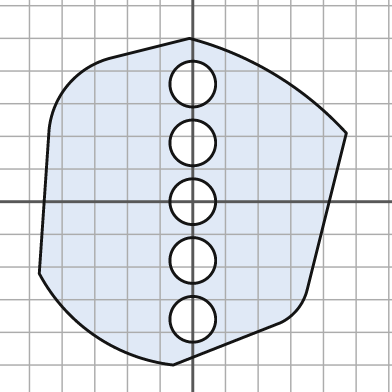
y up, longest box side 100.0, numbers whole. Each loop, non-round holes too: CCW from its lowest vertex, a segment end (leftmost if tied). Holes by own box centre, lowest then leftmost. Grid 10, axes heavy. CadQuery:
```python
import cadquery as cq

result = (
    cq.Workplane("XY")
    .moveTo(-6.0, -50.0)
    .lineTo(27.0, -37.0)
    .threePointArc((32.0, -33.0), (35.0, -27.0))
    .lineTo(47.0, 21.0)
    .threePointArc((25.0, 39.0), (-1.0, 50.0))
    .lineTo(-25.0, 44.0)
    .threePointArc((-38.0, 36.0), (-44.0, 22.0))
    .lineTo(-47.0, -22.0)
    .threePointArc((-30.0, -41.0), (-6.0, -50.0))
    .close()
    .moveTo(0.0, -36.0)
    .circle(7.0)
    .moveTo(0.0, -18.0)
    .circle(7.0)
    .moveTo(0.0, 0.0)
    .circle(7.0)
    .moveTo(0.0, 18.0)
    .circle(7.0)
    .moveTo(0.0, 36.0)
    .circle(7.0)
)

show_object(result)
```